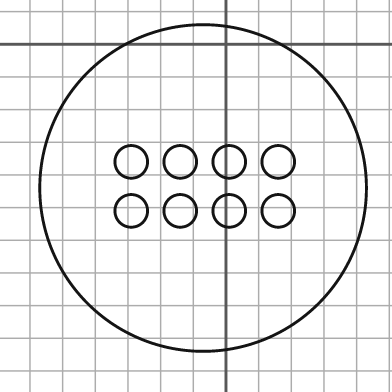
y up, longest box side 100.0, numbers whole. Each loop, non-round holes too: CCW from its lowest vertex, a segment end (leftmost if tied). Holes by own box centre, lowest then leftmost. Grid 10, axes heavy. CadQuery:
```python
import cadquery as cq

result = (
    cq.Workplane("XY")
    .moveTo(-7.0, -44.0)
    .circle(50.0)
    .moveTo(-29.0, -51.0)
    .circle(5.0)
    .moveTo(-14.0, -51.0)
    .circle(5.0)
    .moveTo(1.0, -51.0)
    .circle(5.0)
    .moveTo(16.0, -51.0)
    .circle(5.0)
    .moveTo(-29.0, -36.0)
    .circle(5.0)
    .moveTo(-14.0, -36.0)
    .circle(5.0)
    .moveTo(1.0, -36.0)
    .circle(5.0)
    .moveTo(16.0, -36.0)
    .circle(5.0)
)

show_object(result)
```